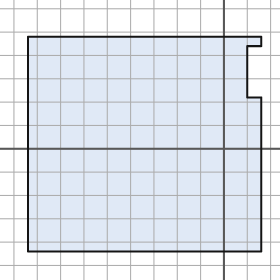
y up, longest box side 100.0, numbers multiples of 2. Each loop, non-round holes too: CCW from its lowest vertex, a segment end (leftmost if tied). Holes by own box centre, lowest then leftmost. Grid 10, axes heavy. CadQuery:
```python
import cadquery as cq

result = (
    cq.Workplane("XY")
    .moveTo(-84.0, -44.0)
    .lineTo(16.0, -44.0)
    .lineTo(16.0, 22.0)
    .lineTo(10.0, 22.0)
    .lineTo(10.0, 44.0)
    .lineTo(16.0, 44.0)
    .lineTo(16.0, 48.0)
    .lineTo(-84.0, 48.0)
    .close()
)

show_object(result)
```